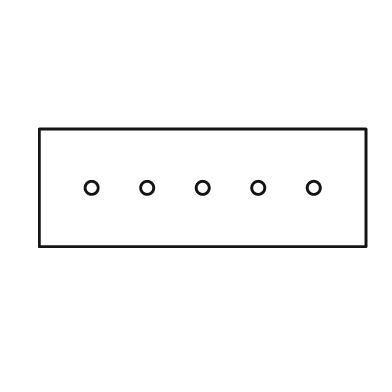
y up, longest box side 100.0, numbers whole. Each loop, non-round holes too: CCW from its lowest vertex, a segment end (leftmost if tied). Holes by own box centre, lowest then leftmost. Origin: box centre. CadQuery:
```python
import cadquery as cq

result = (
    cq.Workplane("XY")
    .moveTo(-50.0, -18.0)
    .lineTo(50.0, -18.0)
    .lineTo(50.0, 18.0)
    .lineTo(-50.0, 18.0)
    .close()
    .moveTo(-34.0, 0.0)
    .circle(2.0)
    .moveTo(-17.0, 0.0)
    .circle(2.0)
    .moveTo(0.0, 0.0)
    .circle(2.0)
    .moveTo(17.0, 0.0)
    .circle(2.0)
    .moveTo(34.0, 0.0)
    .circle(2.0)
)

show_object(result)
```